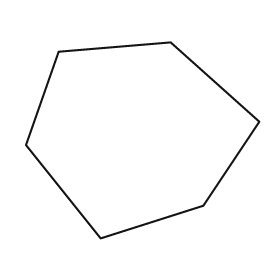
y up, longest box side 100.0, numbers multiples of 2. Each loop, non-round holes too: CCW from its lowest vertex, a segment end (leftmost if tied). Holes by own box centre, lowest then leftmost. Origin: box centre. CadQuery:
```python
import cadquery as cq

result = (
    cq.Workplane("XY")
    .moveTo(-18.0, -42.0)
    .lineTo(26.0, -28.0)
    .lineTo(50.0, 8.0)
    .lineTo(12.0, 42.0)
    .lineTo(-36.0, 38.0)
    .lineTo(-50.0, -2.0)
    .close()
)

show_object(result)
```